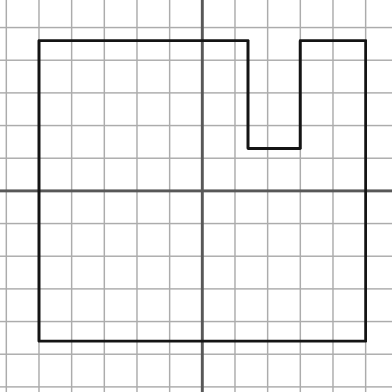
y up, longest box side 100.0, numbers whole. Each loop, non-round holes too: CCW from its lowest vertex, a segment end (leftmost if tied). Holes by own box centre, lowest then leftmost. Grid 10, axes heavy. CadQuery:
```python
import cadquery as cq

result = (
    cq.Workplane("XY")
    .moveTo(-50.0, -46.0)
    .lineTo(50.0, -46.0)
    .lineTo(50.0, 46.0)
    .lineTo(30.0, 46.0)
    .lineTo(30.0, 13.0)
    .lineTo(14.0, 13.0)
    .lineTo(14.0, 46.0)
    .lineTo(-50.0, 46.0)
    .close()
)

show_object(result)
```